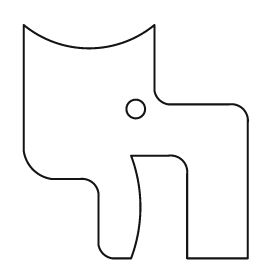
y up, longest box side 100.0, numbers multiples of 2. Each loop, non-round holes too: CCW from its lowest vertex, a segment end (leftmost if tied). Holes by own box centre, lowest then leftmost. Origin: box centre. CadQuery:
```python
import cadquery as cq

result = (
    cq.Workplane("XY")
    .moveTo(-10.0, -50.0)
    .lineTo(-2.0, -50.0)
    .threePointArc((2.0, -28.0), (-2.0, -6.0))
    .lineTo(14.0, -6.0)
    .threePointArc((20.0, -8.0), (22.0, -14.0))
    .lineTo(22.0, -50.0)
    .lineTo(48.0, -50.0)
    .lineTo(48.0, 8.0)
    .threePointArc((46.0, 14.0), (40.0, 16.0))
    .lineTo(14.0, 16.0)
    .threePointArc((10.0, 18.0), (8.0, 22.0))
    .lineTo(8.0, 50.0)
    .threePointArc((-20.0, 40.0), (-48.0, 50.0))
    .lineTo(-48.0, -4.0)
    .threePointArc((-44.0, -12.0), (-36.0, -16.0))
    .lineTo(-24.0, -16.0)
    .threePointArc((-18.0, -18.0), (-16.0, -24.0))
    .lineTo(-16.0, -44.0)
    .threePointArc((-14.0, -48.0), (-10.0, -50.0))
    .close()
    .moveTo(0.0, 14.0)
    .circle(4.0)
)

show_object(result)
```